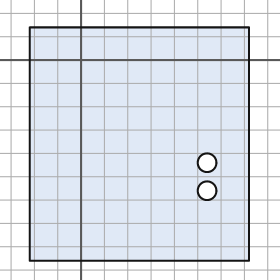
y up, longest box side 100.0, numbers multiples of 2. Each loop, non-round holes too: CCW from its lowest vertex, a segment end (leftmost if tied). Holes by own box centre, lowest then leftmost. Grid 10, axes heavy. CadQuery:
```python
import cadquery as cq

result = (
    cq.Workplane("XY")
    .moveTo(-22.0, -86.0)
    .lineTo(72.0, -86.0)
    .lineTo(72.0, 14.0)
    .lineTo(-22.0, 14.0)
    .close()
    .moveTo(54.0, -56.0)
    .circle(4.0)
    .moveTo(54.0, -44.0)
    .circle(4.0)
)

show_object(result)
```